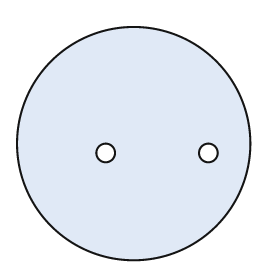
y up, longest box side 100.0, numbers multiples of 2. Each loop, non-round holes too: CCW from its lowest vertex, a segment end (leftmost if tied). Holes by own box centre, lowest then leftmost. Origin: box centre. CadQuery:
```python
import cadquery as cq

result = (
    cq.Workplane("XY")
    .moveTo(0.0, 0.0)
    .circle(50.0)
    .moveTo(-12.0, -4.0)
    .circle(4.0)
    .moveTo(32.0, -4.0)
    .circle(4.0)
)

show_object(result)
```